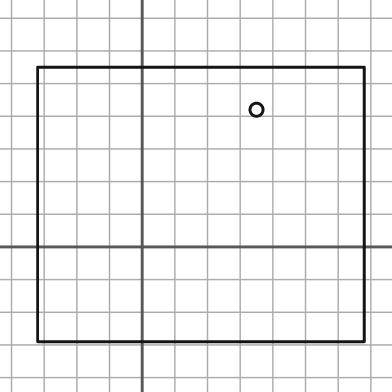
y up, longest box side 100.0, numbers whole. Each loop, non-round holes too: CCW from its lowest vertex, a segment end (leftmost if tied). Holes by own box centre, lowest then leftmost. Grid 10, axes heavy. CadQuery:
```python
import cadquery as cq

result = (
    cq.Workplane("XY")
    .moveTo(-32.0, -29.0)
    .lineTo(68.0, -29.0)
    .lineTo(68.0, 55.0)
    .lineTo(-32.0, 55.0)
    .close()
    .moveTo(35.0, 42.0)
    .circle(2.0)
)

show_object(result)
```